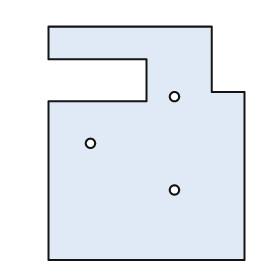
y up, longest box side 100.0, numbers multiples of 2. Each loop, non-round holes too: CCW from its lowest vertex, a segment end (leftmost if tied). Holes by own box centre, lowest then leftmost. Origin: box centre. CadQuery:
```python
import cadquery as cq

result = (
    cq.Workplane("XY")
    .moveTo(-42.0, -50.0)
    .lineTo(42.0, -50.0)
    .lineTo(42.0, 22.0)
    .lineTo(28.0, 22.0)
    .lineTo(28.0, 50.0)
    .lineTo(-42.0, 50.0)
    .lineTo(-42.0, 36.0)
    .lineTo(0.0, 36.0)
    .lineTo(0.0, 18.0)
    .lineTo(-42.0, 18.0)
    .close()
    .moveTo(12.0, -20.0)
    .circle(2.0)
    .moveTo(-24.0, 0.0)
    .circle(2.0)
    .moveTo(12.0, 20.0)
    .circle(2.0)
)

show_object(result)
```